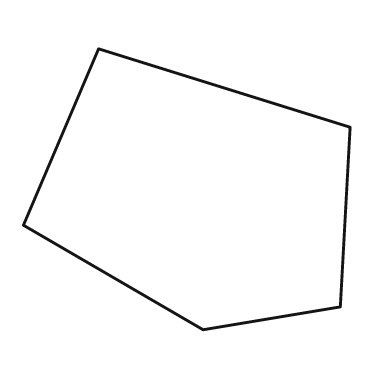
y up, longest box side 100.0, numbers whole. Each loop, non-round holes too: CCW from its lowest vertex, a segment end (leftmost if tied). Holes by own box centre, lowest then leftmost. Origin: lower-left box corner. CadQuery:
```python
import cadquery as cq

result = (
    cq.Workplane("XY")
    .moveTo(55.0, 0.0)
    .lineTo(97.0, 7.0)
    .lineTo(100.0, 62.0)
    .lineTo(23.0, 86.0)
    .lineTo(0.0, 32.0)
    .close()
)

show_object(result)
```